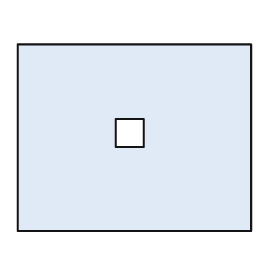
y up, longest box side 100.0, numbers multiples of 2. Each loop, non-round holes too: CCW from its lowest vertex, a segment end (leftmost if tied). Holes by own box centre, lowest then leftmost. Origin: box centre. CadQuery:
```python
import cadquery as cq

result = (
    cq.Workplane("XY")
    .moveTo(-50.0, -40.0)
    .lineTo(50.0, -40.0)
    .lineTo(50.0, 40.0)
    .lineTo(-50.0, 40.0)
    .close()
    .moveTo(-8.0, -4.0)
    .lineTo(4.0, -4.0)
    .lineTo(4.0, 8.0)
    .lineTo(-8.0, 8.0)
    .close()
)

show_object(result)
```